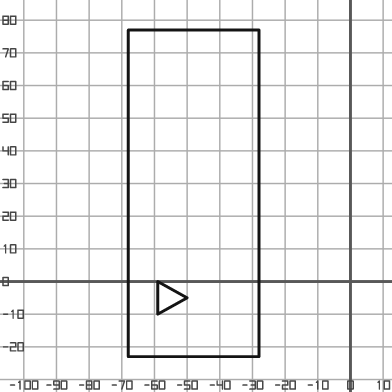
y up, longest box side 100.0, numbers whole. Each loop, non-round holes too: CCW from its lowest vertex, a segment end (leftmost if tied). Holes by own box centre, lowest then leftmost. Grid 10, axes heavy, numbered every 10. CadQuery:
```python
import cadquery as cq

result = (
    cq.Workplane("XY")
    .moveTo(-68.0, -23.0)
    .lineTo(-28.0, -23.0)
    .lineTo(-28.0, 77.0)
    .lineTo(-68.0, 77.0)
    .close()
    .moveTo(-59.0, -10.0)
    .lineTo(-50.0, -5.0)
    .lineTo(-59.0, 0.0)
    .close()
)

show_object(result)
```